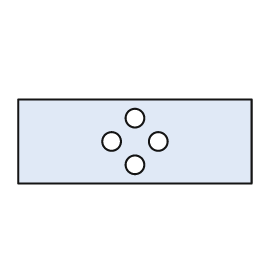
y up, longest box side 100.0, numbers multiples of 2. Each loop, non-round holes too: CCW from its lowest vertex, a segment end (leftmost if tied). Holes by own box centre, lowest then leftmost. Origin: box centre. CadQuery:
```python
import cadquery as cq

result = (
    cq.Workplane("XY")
    .moveTo(-50.0, -18.0)
    .lineTo(50.0, -18.0)
    .lineTo(50.0, 18.0)
    .lineTo(-50.0, 18.0)
    .close()
    .moveTo(0.0, -10.0)
    .circle(4.0)
    .moveTo(-10.0, 0.0)
    .circle(4.0)
    .moveTo(10.0, 0.0)
    .circle(4.0)
    .moveTo(0.0, 10.0)
    .circle(4.0)
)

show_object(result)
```